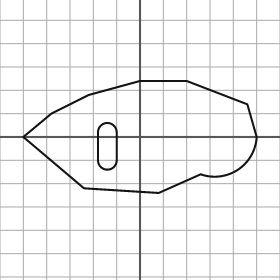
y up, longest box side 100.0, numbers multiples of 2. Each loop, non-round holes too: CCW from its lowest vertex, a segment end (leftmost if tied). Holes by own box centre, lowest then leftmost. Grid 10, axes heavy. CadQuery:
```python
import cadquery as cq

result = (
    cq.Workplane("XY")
    .moveTo(8.0, -24.0)
    .lineTo(26.0, -16.0)
    .threePointArc((42.0, -14.0), (50.0, 0.0))
    .lineTo(46.0, 14.0)
    .lineTo(20.0, 24.0)
    .lineTo(0.0, 24.0)
    .lineTo(-22.0, 18.0)
    .lineTo(-38.0, 10.0)
    .lineTo(-50.0, 0.0)
    .lineTo(-24.0, -22.0)
    .close()
    .moveTo(-18.0, -10.0)
    .threePointArc((-14.0, -14.0), (-10.0, -10.0))
    .lineTo(-10.0, 2.0)
    .threePointArc((-14.0, 6.0), (-18.0, 2.0))
    .close()
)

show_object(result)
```